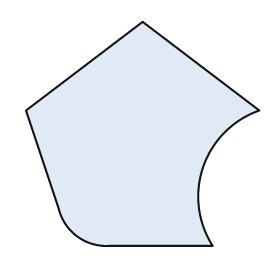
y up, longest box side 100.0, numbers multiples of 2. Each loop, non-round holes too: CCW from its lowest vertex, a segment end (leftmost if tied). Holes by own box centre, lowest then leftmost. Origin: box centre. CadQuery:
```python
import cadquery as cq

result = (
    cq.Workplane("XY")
    .moveTo(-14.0, -48.0)
    .lineTo(30.0, -48.0)
    .threePointArc((26.0, -14.0), (50.0, 10.0))
    .lineTo(0.0, 48.0)
    .lineTo(-50.0, 10.0)
    .lineTo(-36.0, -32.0)
    .threePointArc((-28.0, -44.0), (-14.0, -48.0))
    .close()
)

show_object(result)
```